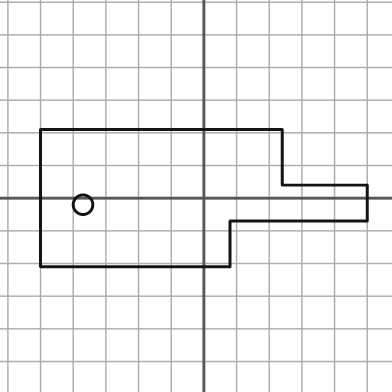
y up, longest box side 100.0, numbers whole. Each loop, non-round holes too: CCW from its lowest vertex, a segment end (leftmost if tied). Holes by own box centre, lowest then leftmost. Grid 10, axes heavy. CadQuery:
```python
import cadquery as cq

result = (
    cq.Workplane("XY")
    .moveTo(-50.0, -21.0)
    .lineTo(8.0, -21.0)
    .lineTo(8.0, -7.0)
    .lineTo(50.0, -7.0)
    .lineTo(50.0, 4.0)
    .lineTo(24.0, 4.0)
    .lineTo(24.0, 21.0)
    .lineTo(-50.0, 21.0)
    .close()
    .moveTo(-37.0, -2.0)
    .circle(3.0)
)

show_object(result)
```